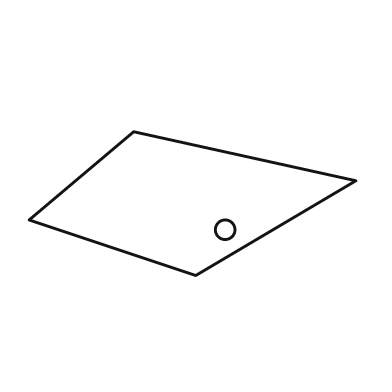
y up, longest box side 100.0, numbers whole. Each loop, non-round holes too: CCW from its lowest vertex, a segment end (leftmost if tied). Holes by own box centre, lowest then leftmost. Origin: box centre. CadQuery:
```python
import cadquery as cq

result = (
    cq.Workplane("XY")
    .moveTo(1.0, -22.0)
    .lineTo(50.0, 7.0)
    .lineTo(-18.0, 22.0)
    .lineTo(-50.0, -5.0)
    .close()
    .moveTo(10.0, -8.0)
    .circle(3.0)
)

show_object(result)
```